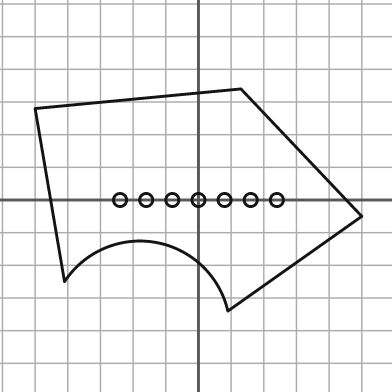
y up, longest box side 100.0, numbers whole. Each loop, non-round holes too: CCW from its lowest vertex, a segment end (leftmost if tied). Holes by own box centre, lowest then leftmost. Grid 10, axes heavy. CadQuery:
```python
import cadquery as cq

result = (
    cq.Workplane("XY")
    .moveTo(9.0, -34.0)
    .lineTo(50.0, -5.0)
    .lineTo(13.0, 34.0)
    .lineTo(-50.0, 28.0)
    .lineTo(-41.0, -25.0)
    .threePointArc((-13.0, -13.0), (9.0, -34.0))
    .close()
    .moveTo(-24.0, 0.0)
    .circle(2.0)
    .moveTo(-16.0, 0.0)
    .circle(2.0)
    .moveTo(-8.0, 0.0)
    .circle(2.0)
    .moveTo(0.0, 0.0)
    .circle(2.0)
    .moveTo(8.0, 0.0)
    .circle(2.0)
    .moveTo(16.0, 0.0)
    .circle(2.0)
    .moveTo(24.0, 0.0)
    .circle(2.0)
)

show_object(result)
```